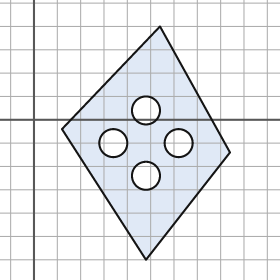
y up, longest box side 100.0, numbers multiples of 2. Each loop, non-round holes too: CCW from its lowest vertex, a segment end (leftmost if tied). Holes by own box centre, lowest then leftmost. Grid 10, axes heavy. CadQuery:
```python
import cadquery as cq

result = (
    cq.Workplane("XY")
    .moveTo(48.0, -60.0)
    .lineTo(84.0, -14.0)
    .lineTo(54.0, 40.0)
    .lineTo(12.0, -4.0)
    .close()
    .moveTo(48.0, -24.0)
    .circle(6.0)
    .moveTo(34.0, -10.0)
    .circle(6.0)
    .moveTo(62.0, -10.0)
    .circle(6.0)
    .moveTo(48.0, 4.0)
    .circle(6.0)
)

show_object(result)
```